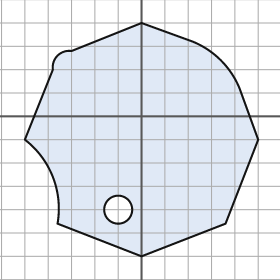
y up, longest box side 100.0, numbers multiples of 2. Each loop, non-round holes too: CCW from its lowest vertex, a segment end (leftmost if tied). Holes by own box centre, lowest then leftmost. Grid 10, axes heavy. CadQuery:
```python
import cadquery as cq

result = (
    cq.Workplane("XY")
    .moveTo(0.0, -60.0)
    .lineTo(36.0, -46.0)
    .lineTo(50.0, -10.0)
    .lineTo(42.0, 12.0)
    .threePointArc((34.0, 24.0), (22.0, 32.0))
    .lineTo(0.0, 40.0)
    .lineTo(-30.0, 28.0)
    .threePointArc((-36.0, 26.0), (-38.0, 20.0))
    .lineTo(-50.0, -10.0)
    .threePointArc((-38.0, -26.0), (-36.0, -46.0))
    .close()
    .moveTo(-10.0, -40.0)
    .circle(6.0)
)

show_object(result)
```